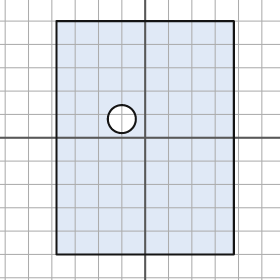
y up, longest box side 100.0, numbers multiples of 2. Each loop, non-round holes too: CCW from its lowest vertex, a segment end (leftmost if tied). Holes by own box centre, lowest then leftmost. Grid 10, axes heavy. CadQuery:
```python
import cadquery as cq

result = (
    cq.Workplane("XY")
    .moveTo(-38.0, -50.0)
    .lineTo(38.0, -50.0)
    .lineTo(38.0, 50.0)
    .lineTo(-38.0, 50.0)
    .close()
    .moveTo(-10.0, 8.0)
    .circle(6.0)
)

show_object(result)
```